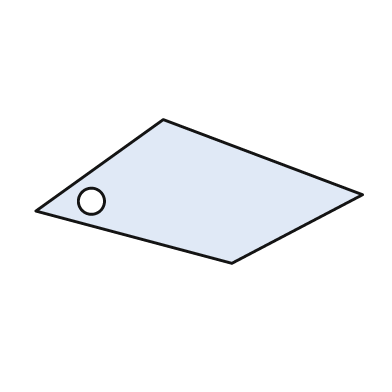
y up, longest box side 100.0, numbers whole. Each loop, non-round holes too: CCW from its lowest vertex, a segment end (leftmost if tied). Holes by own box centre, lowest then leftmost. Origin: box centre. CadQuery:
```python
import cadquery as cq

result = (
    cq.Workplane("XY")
    .moveTo(10.0, -22.0)
    .lineTo(50.0, -1.0)
    .lineTo(-11.0, 22.0)
    .lineTo(-50.0, -6.0)
    .close()
    .moveTo(-33.0, -3.0)
    .circle(4.0)
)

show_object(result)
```